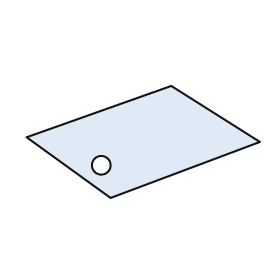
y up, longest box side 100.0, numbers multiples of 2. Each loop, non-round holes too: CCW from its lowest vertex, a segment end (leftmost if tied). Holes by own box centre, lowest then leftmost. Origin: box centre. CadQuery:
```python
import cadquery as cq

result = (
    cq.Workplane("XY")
    .moveTo(-14.0, -24.0)
    .lineTo(50.0, 0.0)
    .lineTo(12.0, 24.0)
    .lineTo(-50.0, 2.0)
    .close()
    .moveTo(-18.0, -10.0)
    .circle(4.0)
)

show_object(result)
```